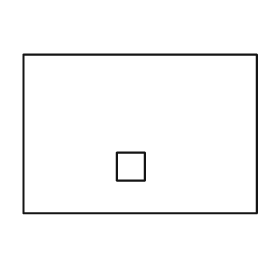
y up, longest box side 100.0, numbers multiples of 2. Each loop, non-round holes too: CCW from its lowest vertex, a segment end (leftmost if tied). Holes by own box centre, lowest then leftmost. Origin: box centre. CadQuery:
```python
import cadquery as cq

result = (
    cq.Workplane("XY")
    .moveTo(-50.0, -34.0)
    .lineTo(50.0, -34.0)
    .lineTo(50.0, 34.0)
    .lineTo(-50.0, 34.0)
    .close()
    .moveTo(-10.0, -20.0)
    .lineTo(2.0, -20.0)
    .lineTo(2.0, -8.0)
    .lineTo(-10.0, -8.0)
    .close()
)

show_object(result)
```